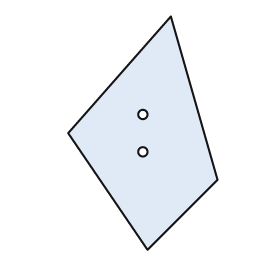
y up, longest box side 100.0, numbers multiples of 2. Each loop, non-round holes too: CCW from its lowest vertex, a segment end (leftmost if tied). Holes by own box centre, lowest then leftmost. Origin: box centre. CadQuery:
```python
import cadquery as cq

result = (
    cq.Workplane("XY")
    .moveTo(2.0, -50.0)
    .lineTo(32.0, -20.0)
    .lineTo(12.0, 50.0)
    .lineTo(-32.0, 0.0)
    .close()
    .moveTo(0.0, -8.0)
    .circle(2.0)
    .moveTo(0.0, 8.0)
    .circle(2.0)
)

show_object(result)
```